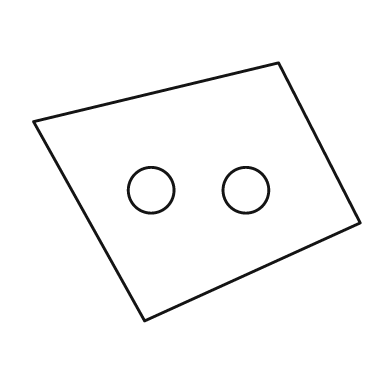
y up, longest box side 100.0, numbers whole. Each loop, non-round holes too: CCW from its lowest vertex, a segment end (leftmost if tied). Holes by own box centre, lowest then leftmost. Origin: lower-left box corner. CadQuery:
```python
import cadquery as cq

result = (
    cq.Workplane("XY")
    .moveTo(34.0, 0.0)
    .lineTo(100.0, 30.0)
    .lineTo(75.0, 79.0)
    .lineTo(0.0, 61.0)
    .close()
    .moveTo(36.0, 40.0)
    .circle(7.0)
    .moveTo(65.0, 40.0)
    .circle(7.0)
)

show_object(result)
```